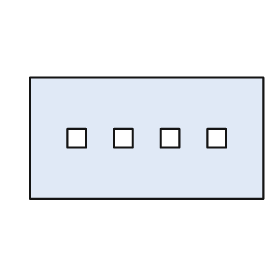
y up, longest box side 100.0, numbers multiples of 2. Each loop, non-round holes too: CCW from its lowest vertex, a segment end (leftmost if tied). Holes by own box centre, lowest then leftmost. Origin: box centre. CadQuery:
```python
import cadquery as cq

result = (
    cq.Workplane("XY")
    .moveTo(-50.0, -26.0)
    .lineTo(50.0, -26.0)
    .lineTo(50.0, 26.0)
    .lineTo(-50.0, 26.0)
    .close()
    .moveTo(-34.0, -4.0)
    .lineTo(-26.0, -4.0)
    .lineTo(-26.0, 4.0)
    .lineTo(-34.0, 4.0)
    .close()
    .moveTo(-14.0, -4.0)
    .lineTo(-6.0, -4.0)
    .lineTo(-6.0, 4.0)
    .lineTo(-14.0, 4.0)
    .close()
    .moveTo(6.0, -4.0)
    .lineTo(14.0, -4.0)
    .lineTo(14.0, 4.0)
    .lineTo(6.0, 4.0)
    .close()
    .moveTo(26.0, -4.0)
    .lineTo(34.0, -4.0)
    .lineTo(34.0, 4.0)
    .lineTo(26.0, 4.0)
    .close()
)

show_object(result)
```